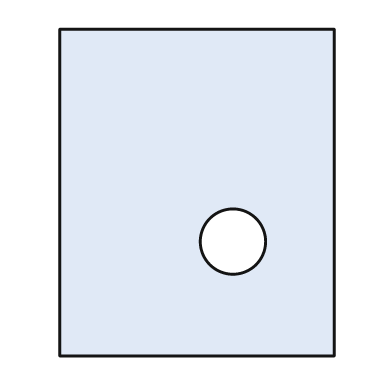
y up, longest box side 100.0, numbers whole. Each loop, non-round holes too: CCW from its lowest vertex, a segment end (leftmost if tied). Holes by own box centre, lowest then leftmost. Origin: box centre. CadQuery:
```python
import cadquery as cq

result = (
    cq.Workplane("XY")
    .moveTo(-42.0, -50.0)
    .lineTo(42.0, -50.0)
    .lineTo(42.0, 50.0)
    .lineTo(-42.0, 50.0)
    .close()
    .moveTo(11.0, -15.0)
    .circle(10.0)
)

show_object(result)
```